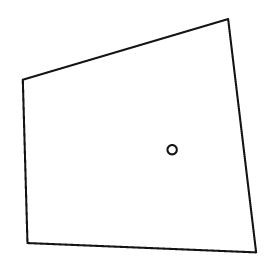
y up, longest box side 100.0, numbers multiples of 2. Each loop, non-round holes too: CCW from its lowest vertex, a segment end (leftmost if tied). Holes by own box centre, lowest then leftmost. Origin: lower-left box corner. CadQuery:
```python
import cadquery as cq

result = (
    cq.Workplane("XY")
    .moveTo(100.0, 0.0)
    .lineTo(88.0, 100.0)
    .lineTo(0.0, 74.0)
    .lineTo(2.0, 4.0)
    .close()
    .moveTo(64.0, 44.0)
    .circle(2.0)
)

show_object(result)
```